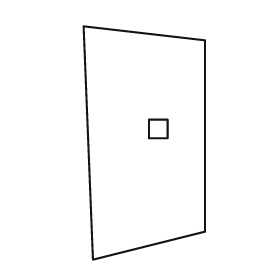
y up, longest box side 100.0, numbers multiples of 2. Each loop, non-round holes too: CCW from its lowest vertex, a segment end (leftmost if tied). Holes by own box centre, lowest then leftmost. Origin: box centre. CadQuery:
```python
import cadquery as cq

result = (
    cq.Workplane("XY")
    .moveTo(-22.0, -50.0)
    .lineTo(26.0, -38.0)
    .lineTo(26.0, 44.0)
    .lineTo(-26.0, 50.0)
    .close()
    .moveTo(2.0, 2.0)
    .lineTo(10.0, 2.0)
    .lineTo(10.0, 10.0)
    .lineTo(2.0, 10.0)
    .close()
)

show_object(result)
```